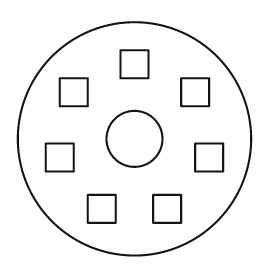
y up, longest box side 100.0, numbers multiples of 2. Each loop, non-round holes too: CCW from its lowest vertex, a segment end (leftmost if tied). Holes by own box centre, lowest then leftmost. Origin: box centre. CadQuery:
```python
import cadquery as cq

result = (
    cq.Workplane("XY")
    .moveTo(0.0, 0.0)
    .circle(50.0)
    .moveTo(-20.0, -36.0)
    .lineTo(-8.0, -36.0)
    .lineTo(-8.0, -24.0)
    .lineTo(-20.0, -24.0)
    .close()
    .moveTo(8.0, -36.0)
    .lineTo(20.0, -36.0)
    .lineTo(20.0, -24.0)
    .lineTo(8.0, -24.0)
    .close()
    .moveTo(-38.0, -14.0)
    .lineTo(-26.0, -14.0)
    .lineTo(-26.0, -2.0)
    .lineTo(-38.0, -2.0)
    .close()
    .moveTo(26.0, -14.0)
    .lineTo(38.0, -14.0)
    .lineTo(38.0, -2.0)
    .lineTo(26.0, -2.0)
    .close()
    .moveTo(0.0, 0.0)
    .circle(12.0)
    .moveTo(-32.0, 14.0)
    .lineTo(-20.0, 14.0)
    .lineTo(-20.0, 26.0)
    .lineTo(-32.0, 26.0)
    .close()
    .moveTo(20.0, 14.0)
    .lineTo(32.0, 14.0)
    .lineTo(32.0, 26.0)
    .lineTo(20.0, 26.0)
    .close()
    .moveTo(-6.0, 26.0)
    .lineTo(6.0, 26.0)
    .lineTo(6.0, 38.0)
    .lineTo(-6.0, 38.0)
    .close()
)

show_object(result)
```